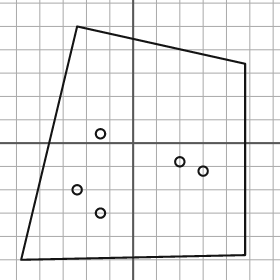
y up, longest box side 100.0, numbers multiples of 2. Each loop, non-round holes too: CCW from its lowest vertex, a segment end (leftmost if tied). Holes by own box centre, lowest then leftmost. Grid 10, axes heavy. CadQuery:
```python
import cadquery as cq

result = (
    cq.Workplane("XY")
    .moveTo(-48.0, -50.0)
    .lineTo(48.0, -48.0)
    .lineTo(48.0, 34.0)
    .lineTo(-24.0, 50.0)
    .close()
    .moveTo(-14.0, -30.0)
    .circle(2.0)
    .moveTo(-24.0, -20.0)
    .circle(2.0)
    .moveTo(30.0, -12.0)
    .circle(2.0)
    .moveTo(20.0, -8.0)
    .circle(2.0)
    .moveTo(-14.0, 4.0)
    .circle(2.0)
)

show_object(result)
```